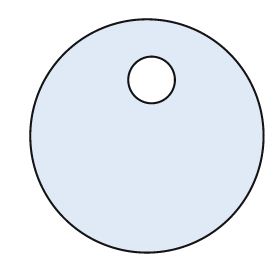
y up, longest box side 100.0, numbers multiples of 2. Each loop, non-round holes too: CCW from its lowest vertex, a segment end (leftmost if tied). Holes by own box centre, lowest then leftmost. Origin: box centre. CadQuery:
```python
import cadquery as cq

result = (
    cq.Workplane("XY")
    .moveTo(0.0, 0.0)
    .circle(50.0)
    .moveTo(2.0, 24.0)
    .circle(10.0)
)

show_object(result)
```